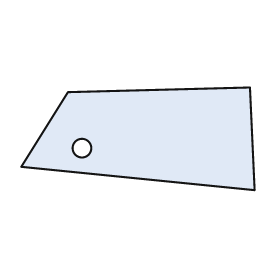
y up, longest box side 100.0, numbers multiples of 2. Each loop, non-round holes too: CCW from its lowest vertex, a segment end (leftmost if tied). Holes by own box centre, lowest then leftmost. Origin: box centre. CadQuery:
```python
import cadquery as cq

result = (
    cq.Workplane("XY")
    .moveTo(50.0, -22.0)
    .lineTo(48.0, 22.0)
    .lineTo(-30.0, 20.0)
    .lineTo(-50.0, -12.0)
    .close()
    .moveTo(-24.0, -4.0)
    .circle(4.0)
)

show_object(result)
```